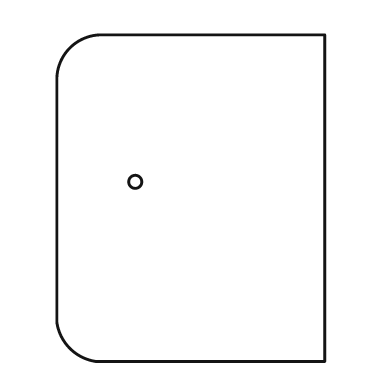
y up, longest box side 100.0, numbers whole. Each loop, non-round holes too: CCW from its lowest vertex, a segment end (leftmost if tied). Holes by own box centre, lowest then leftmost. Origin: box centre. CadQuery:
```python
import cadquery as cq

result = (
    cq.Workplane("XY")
    .moveTo(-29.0, -50.0)
    .lineTo(41.0, -50.0)
    .lineTo(41.0, 50.0)
    .lineTo(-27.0, 50.0)
    .threePointArc((-37.0, 46.0), (-41.0, 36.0))
    .lineTo(-41.0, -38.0)
    .threePointArc((-37.0, -46.0), (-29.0, -50.0))
    .close()
    .moveTo(-17.0, 5.0)
    .circle(2.0)
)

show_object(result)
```